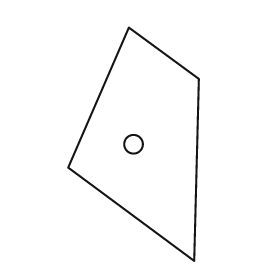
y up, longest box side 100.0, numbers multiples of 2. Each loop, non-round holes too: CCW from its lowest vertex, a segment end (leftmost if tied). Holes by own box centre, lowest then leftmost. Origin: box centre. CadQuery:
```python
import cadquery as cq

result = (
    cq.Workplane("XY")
    .moveTo(26.0, -50.0)
    .lineTo(28.0, 28.0)
    .lineTo(-2.0, 50.0)
    .lineTo(-28.0, -10.0)
    .close()
    .moveTo(0.0, 0.0)
    .circle(4.0)
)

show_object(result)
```